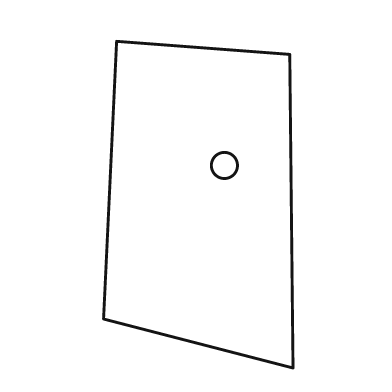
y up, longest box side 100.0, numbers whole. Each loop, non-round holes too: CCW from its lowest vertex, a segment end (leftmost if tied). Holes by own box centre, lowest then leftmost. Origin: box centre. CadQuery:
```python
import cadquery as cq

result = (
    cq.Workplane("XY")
    .moveTo(29.0, -50.0)
    .lineTo(28.0, 46.0)
    .lineTo(-25.0, 50.0)
    .lineTo(-29.0, -35.0)
    .close()
    .moveTo(8.0, 12.0)
    .circle(4.0)
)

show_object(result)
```